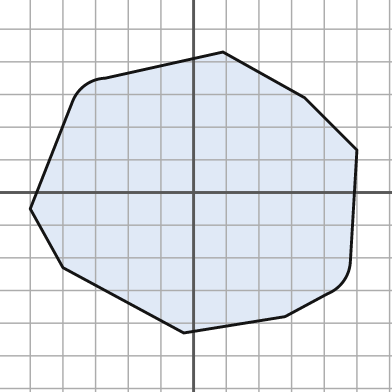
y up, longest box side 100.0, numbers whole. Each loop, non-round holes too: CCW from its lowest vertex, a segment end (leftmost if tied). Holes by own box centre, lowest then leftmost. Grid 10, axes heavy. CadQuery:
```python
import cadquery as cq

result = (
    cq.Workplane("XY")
    .moveTo(-3.0, -43.0)
    .lineTo(28.0, -38.0)
    .lineTo(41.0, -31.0)
    .threePointArc((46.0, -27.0), (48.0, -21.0))
    .lineTo(50.0, 13.0)
    .lineTo(34.0, 29.0)
    .lineTo(9.0, 43.0)
    .lineTo(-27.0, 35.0)
    .threePointArc((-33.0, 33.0), (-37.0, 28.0))
    .lineTo(-50.0, -5.0)
    .lineTo(-40.0, -23.0)
    .close()
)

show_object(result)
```